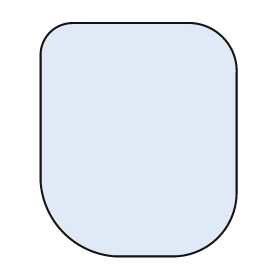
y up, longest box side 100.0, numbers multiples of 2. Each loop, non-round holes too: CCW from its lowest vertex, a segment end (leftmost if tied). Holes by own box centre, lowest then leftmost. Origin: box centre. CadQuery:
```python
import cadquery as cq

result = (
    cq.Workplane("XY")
    .moveTo(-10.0, -50.0)
    .lineTo(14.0, -50.0)
    .threePointArc((34.0, -42.0), (42.0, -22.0))
    .lineTo(42.0, 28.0)
    .threePointArc((36.0, 44.0), (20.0, 50.0))
    .lineTo(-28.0, 50.0)
    .threePointArc((-38.0, 46.0), (-42.0, 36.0))
    .lineTo(-42.0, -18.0)
    .threePointArc((-32.0, -40.0), (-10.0, -50.0))
    .close()
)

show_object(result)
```